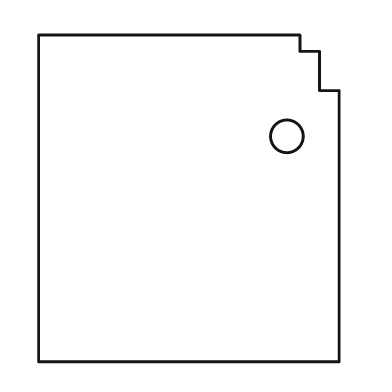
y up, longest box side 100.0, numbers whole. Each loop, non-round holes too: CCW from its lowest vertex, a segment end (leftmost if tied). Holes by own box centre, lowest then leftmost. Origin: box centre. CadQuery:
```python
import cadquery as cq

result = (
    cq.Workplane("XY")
    .moveTo(-46.0, -50.0)
    .lineTo(46.0, -50.0)
    .lineTo(46.0, 33.0)
    .lineTo(40.0, 33.0)
    .lineTo(40.0, 45.0)
    .lineTo(34.0, 45.0)
    .lineTo(34.0, 50.0)
    .lineTo(-46.0, 50.0)
    .close()
    .moveTo(30.0, 19.0)
    .circle(5.0)
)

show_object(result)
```